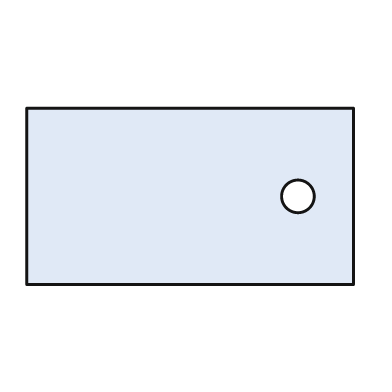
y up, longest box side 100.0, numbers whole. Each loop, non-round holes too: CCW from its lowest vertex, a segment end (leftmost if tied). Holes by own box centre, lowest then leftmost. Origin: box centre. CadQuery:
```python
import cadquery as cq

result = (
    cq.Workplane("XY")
    .moveTo(-50.0, -27.0)
    .lineTo(50.0, -27.0)
    .lineTo(50.0, 27.0)
    .lineTo(-50.0, 27.0)
    .close()
    .moveTo(33.0, 0.0)
    .circle(5.0)
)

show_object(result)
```